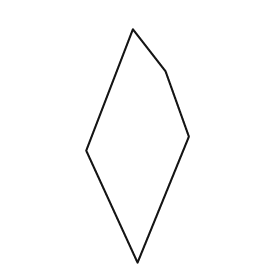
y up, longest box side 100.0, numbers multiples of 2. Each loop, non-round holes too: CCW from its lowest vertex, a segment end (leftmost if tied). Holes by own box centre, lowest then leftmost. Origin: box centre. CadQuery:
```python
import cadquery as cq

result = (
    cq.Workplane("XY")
    .moveTo(0.0, -50.0)
    .lineTo(22.0, 4.0)
    .lineTo(12.0, 32.0)
    .lineTo(-2.0, 50.0)
    .lineTo(-22.0, -2.0)
    .close()
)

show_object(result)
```